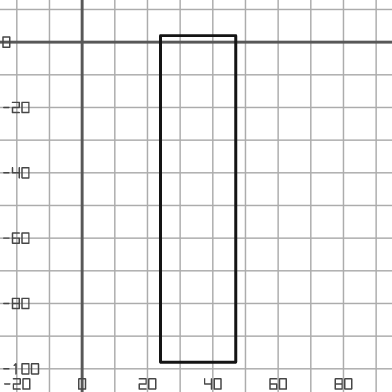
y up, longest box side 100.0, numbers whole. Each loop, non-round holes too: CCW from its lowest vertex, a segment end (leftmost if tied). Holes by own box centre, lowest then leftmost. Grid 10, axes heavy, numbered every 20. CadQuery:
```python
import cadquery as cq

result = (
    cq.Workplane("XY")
    .moveTo(24.0, -98.0)
    .lineTo(47.0, -98.0)
    .lineTo(47.0, 2.0)
    .lineTo(24.0, 2.0)
    .close()
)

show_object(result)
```